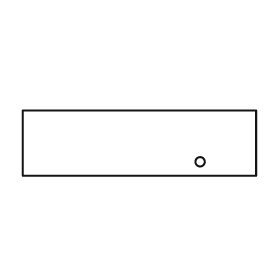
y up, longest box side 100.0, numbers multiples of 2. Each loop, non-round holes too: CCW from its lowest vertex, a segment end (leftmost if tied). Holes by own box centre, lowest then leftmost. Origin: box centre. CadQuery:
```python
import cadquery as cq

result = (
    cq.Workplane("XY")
    .moveTo(-50.0, -14.0)
    .lineTo(50.0, -14.0)
    .lineTo(50.0, 14.0)
    .lineTo(-50.0, 14.0)
    .close()
    .moveTo(26.0, -8.0)
    .circle(2.0)
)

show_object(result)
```